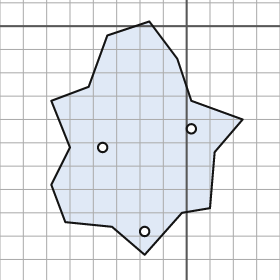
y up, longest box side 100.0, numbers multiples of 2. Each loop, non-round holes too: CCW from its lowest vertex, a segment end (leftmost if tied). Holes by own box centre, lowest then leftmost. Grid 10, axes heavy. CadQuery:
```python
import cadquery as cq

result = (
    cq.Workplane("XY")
    .moveTo(-18.0, -98.0)
    .lineTo(-2.0, -80.0)
    .lineTo(10.0, -78.0)
    .lineTo(12.0, -54.0)
    .lineTo(24.0, -40.0)
    .lineTo(2.0, -32.0)
    .lineTo(-4.0, -14.0)
    .lineTo(-16.0, 2.0)
    .lineTo(-34.0, -4.0)
    .lineTo(-42.0, -26.0)
    .lineTo(-58.0, -32.0)
    .lineTo(-50.0, -52.0)
    .lineTo(-58.0, -68.0)
    .lineTo(-52.0, -84.0)
    .lineTo(-32.0, -86.0)
    .close()
    .moveTo(-18.0, -88.0)
    .circle(2.0)
    .moveTo(-36.0, -52.0)
    .circle(2.0)
    .moveTo(2.0, -44.0)
    .circle(2.0)
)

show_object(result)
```